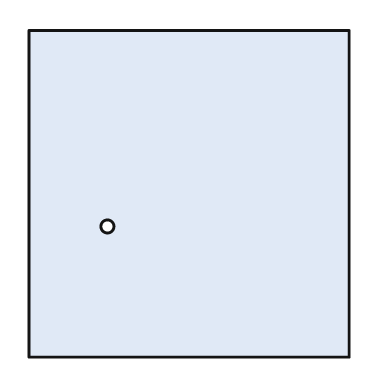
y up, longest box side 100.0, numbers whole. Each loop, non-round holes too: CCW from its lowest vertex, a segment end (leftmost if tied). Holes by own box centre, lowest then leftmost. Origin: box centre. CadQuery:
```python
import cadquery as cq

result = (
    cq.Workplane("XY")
    .moveTo(-49.0, -50.0)
    .lineTo(49.0, -50.0)
    .lineTo(49.0, 50.0)
    .lineTo(-49.0, 50.0)
    .close()
    .moveTo(-25.0, -10.0)
    .circle(2.0)
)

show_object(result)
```